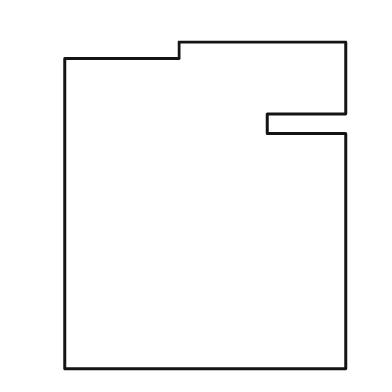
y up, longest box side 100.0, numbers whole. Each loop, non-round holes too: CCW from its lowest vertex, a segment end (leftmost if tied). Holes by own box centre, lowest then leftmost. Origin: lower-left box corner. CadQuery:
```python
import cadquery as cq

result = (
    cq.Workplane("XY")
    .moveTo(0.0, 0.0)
    .lineTo(86.0, 0.0)
    .lineTo(86.0, 72.0)
    .lineTo(62.0, 72.0)
    .lineTo(62.0, 78.0)
    .lineTo(86.0, 78.0)
    .lineTo(86.0, 100.0)
    .lineTo(35.0, 100.0)
    .lineTo(35.0, 95.0)
    .lineTo(0.0, 95.0)
    .close()
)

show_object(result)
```